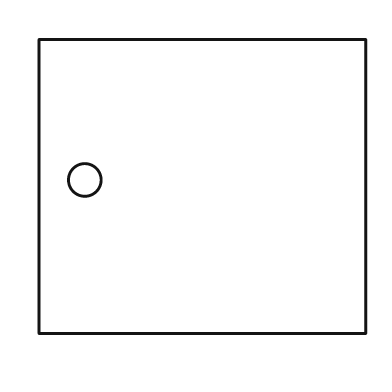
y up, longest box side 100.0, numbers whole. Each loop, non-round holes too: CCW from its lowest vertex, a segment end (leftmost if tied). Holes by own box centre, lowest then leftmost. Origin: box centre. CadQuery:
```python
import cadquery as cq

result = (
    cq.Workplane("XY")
    .moveTo(-50.0, -45.0)
    .lineTo(50.0, -45.0)
    .lineTo(50.0, 45.0)
    .lineTo(-50.0, 45.0)
    .close()
    .moveTo(-36.0, 2.0)
    .circle(5.0)
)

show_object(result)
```